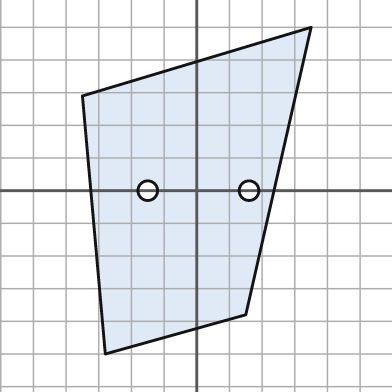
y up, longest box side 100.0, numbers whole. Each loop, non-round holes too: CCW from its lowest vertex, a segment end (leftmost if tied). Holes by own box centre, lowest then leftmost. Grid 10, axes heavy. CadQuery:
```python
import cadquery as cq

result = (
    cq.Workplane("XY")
    .moveTo(-28.0, -50.0)
    .lineTo(15.0, -38.0)
    .lineTo(35.0, 50.0)
    .lineTo(-35.0, 29.0)
    .close()
    .moveTo(-15.0, 0.0)
    .circle(3.0)
    .moveTo(16.0, 0.0)
    .circle(3.0)
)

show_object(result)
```